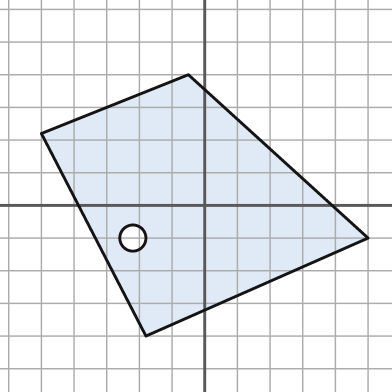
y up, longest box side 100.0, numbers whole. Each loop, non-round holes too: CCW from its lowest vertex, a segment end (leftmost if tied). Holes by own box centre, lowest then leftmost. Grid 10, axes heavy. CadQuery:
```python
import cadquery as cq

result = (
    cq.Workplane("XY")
    .moveTo(-18.0, -40.0)
    .lineTo(50.0, -10.0)
    .lineTo(-5.0, 40.0)
    .lineTo(-50.0, 22.0)
    .close()
    .moveTo(-22.0, -10.0)
    .circle(4.0)
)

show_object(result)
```